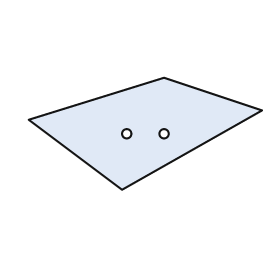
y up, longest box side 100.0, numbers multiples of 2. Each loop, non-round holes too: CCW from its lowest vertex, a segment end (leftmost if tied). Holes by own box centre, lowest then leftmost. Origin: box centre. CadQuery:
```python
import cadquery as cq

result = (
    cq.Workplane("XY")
    .moveTo(-10.0, -24.0)
    .lineTo(50.0, 10.0)
    .lineTo(8.0, 24.0)
    .lineTo(-50.0, 6.0)
    .close()
    .moveTo(-8.0, 0.0)
    .circle(2.0)
    .moveTo(8.0, 0.0)
    .circle(2.0)
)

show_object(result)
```